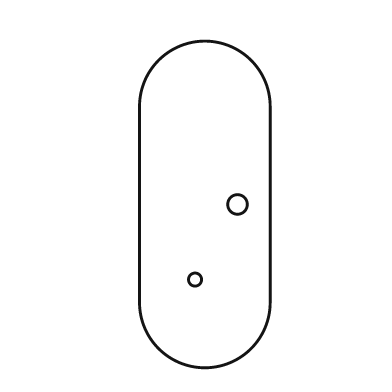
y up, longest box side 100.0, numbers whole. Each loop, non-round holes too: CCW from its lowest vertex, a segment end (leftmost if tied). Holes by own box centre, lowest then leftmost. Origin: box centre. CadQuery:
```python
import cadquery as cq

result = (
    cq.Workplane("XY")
    .moveTo(-20.0, -30.0)
    .threePointArc((0.0, -50.0), (20.0, -30.0))
    .lineTo(20.0, 30.0)
    .threePointArc((0.0, 50.0), (-20.0, 30.0))
    .close()
    .moveTo(-3.0, -23.0)
    .circle(2.0)
    .moveTo(10.0, 0.0)
    .circle(3.0)
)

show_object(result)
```